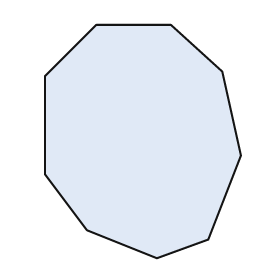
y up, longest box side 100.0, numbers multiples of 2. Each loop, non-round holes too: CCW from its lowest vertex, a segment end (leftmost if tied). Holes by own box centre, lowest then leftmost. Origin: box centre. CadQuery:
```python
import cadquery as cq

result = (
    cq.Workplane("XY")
    .moveTo(6.0, -50.0)
    .lineTo(28.0, -42.0)
    .lineTo(42.0, -6.0)
    .lineTo(34.0, 30.0)
    .lineTo(12.0, 50.0)
    .lineTo(-20.0, 50.0)
    .lineTo(-42.0, 28.0)
    .lineTo(-42.0, -14.0)
    .lineTo(-24.0, -38.0)
    .close()
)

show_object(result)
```